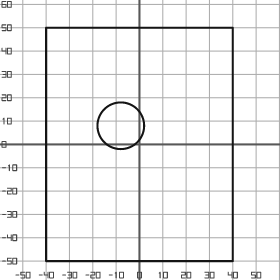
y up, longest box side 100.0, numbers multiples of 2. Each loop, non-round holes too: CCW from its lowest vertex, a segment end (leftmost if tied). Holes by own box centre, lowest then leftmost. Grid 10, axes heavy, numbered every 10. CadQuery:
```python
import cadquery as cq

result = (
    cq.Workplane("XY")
    .moveTo(-40.0, -50.0)
    .lineTo(40.0, -50.0)
    .lineTo(40.0, 50.0)
    .lineTo(-40.0, 50.0)
    .close()
    .moveTo(-8.0, 8.0)
    .circle(10.0)
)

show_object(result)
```